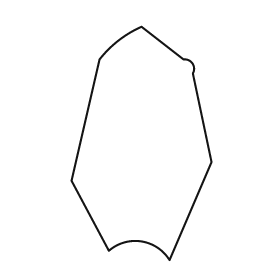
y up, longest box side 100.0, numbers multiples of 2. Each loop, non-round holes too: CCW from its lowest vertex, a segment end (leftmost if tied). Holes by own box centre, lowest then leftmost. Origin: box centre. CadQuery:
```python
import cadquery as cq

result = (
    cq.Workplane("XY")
    .moveTo(12.0, -50.0)
    .lineTo(30.0, -8.0)
    .lineTo(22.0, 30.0)
    .threePointArc((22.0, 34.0), (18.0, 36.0))
    .lineTo(0.0, 50.0)
    .threePointArc((-10.0, 44.0), (-18.0, 36.0))
    .lineTo(-30.0, -16.0)
    .lineTo(-14.0, -46.0)
    .threePointArc((0.0, -42.0), (12.0, -50.0))
    .close()
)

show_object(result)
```